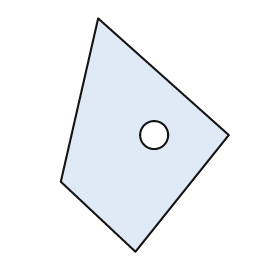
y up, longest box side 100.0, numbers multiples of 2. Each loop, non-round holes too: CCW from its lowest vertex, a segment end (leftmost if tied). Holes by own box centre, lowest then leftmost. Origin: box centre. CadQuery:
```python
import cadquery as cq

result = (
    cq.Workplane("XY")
    .moveTo(-4.0, -50.0)
    .lineTo(36.0, 0.0)
    .lineTo(-20.0, 50.0)
    .lineTo(-36.0, -20.0)
    .close()
    .moveTo(4.0, 0.0)
    .circle(6.0)
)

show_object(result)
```